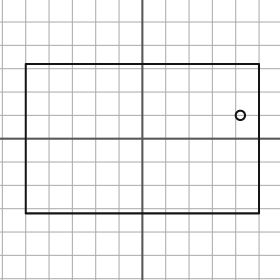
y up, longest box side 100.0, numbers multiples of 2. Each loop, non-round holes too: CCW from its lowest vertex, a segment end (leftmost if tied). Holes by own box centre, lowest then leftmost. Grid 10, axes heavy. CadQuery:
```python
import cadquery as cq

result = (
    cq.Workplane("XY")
    .moveTo(-50.0, -32.0)
    .lineTo(50.0, -32.0)
    .lineTo(50.0, 32.0)
    .lineTo(-50.0, 32.0)
    .close()
    .moveTo(42.0, 10.0)
    .circle(2.0)
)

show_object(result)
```